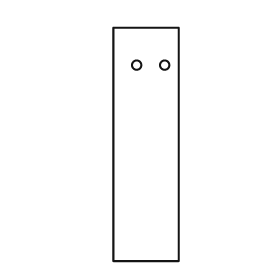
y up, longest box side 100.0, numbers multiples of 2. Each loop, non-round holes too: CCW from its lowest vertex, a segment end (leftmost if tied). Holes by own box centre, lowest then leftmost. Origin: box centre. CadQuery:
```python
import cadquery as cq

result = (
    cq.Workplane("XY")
    .moveTo(-14.0, -50.0)
    .lineTo(14.0, -50.0)
    .lineTo(14.0, 50.0)
    .lineTo(-14.0, 50.0)
    .close()
    .moveTo(-4.0, 34.0)
    .circle(2.0)
    .moveTo(8.0, 34.0)
    .circle(2.0)
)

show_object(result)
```